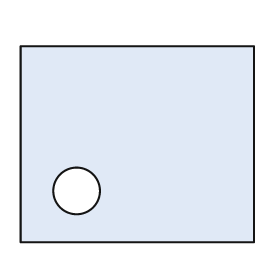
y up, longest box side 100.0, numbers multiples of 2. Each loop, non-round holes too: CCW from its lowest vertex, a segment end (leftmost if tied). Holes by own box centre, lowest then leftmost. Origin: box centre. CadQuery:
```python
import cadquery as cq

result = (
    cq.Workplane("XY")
    .moveTo(-50.0, -42.0)
    .lineTo(50.0, -42.0)
    .lineTo(50.0, 42.0)
    .lineTo(-50.0, 42.0)
    .close()
    .moveTo(-26.0, -20.0)
    .circle(10.0)
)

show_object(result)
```